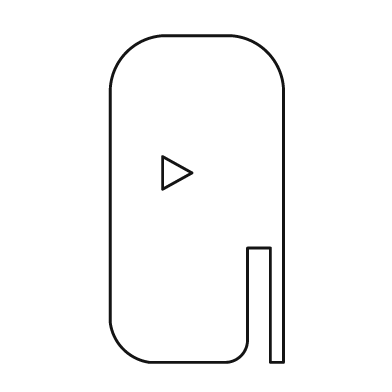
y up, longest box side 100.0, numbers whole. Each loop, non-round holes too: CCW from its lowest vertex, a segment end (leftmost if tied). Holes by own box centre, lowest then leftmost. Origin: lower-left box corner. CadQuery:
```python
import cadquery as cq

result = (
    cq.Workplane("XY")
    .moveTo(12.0, 0.0)
    .lineTo(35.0, 0.0)
    .threePointArc((40.0, 2.0), (42.0, 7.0))
    .lineTo(42.0, 35.0)
    .lineTo(49.0, 35.0)
    .lineTo(49.0, 0.0)
    .lineTo(53.0, 0.0)
    .lineTo(53.0, 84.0)
    .threePointArc((48.0, 95.0), (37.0, 100.0))
    .lineTo(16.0, 100.0)
    .threePointArc((5.0, 95.0), (0.0, 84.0))
    .lineTo(0.0, 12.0)
    .threePointArc((4.0, 4.0), (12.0, 0.0))
    .close()
    .moveTo(16.0, 53.0)
    .lineTo(25.0, 58.0)
    .lineTo(16.0, 63.0)
    .close()
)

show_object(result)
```